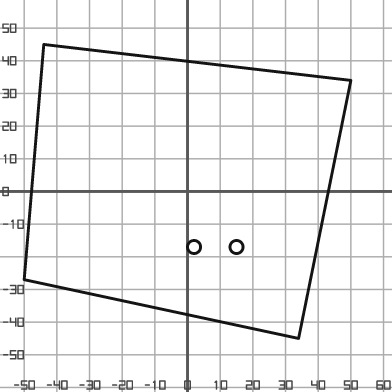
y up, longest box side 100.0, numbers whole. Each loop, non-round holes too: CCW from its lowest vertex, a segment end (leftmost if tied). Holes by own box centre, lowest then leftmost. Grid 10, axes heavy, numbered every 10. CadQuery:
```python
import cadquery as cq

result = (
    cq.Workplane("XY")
    .moveTo(34.0, -45.0)
    .lineTo(50.0, 34.0)
    .lineTo(-44.0, 45.0)
    .lineTo(-50.0, -27.0)
    .close()
    .moveTo(2.0, -17.0)
    .circle(2.0)
    .moveTo(15.0, -17.0)
    .circle(2.0)
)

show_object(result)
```